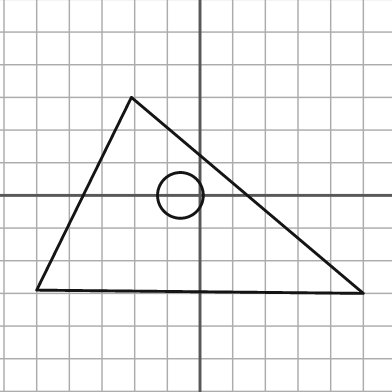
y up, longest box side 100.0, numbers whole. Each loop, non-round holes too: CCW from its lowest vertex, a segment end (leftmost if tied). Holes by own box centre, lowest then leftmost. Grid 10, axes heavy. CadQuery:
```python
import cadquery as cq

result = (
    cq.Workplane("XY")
    .moveTo(50.0, -30.0)
    .lineTo(-21.0, 30.0)
    .lineTo(-50.0, -29.0)
    .close()
    .moveTo(-6.0, 0.0)
    .circle(7.0)
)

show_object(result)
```